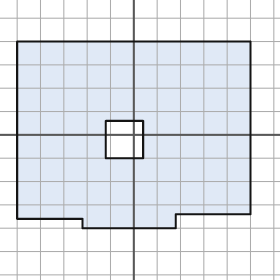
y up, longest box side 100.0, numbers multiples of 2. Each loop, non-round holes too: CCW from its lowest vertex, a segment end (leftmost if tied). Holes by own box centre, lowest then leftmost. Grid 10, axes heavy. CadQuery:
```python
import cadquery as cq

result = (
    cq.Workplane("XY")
    .moveTo(-22.0, -40.0)
    .lineTo(18.0, -40.0)
    .lineTo(18.0, -34.0)
    .lineTo(50.0, -34.0)
    .lineTo(50.0, 40.0)
    .lineTo(-50.0, 40.0)
    .lineTo(-50.0, -36.0)
    .lineTo(-22.0, -36.0)
    .close()
    .moveTo(-12.0, -10.0)
    .lineTo(4.0, -10.0)
    .lineTo(4.0, 6.0)
    .lineTo(-12.0, 6.0)
    .close()
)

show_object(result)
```